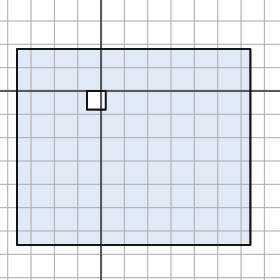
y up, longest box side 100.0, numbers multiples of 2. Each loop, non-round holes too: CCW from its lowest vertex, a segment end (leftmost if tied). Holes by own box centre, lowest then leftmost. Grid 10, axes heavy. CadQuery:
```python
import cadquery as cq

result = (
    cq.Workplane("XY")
    .moveTo(-36.0, -66.0)
    .lineTo(64.0, -66.0)
    .lineTo(64.0, 18.0)
    .lineTo(-36.0, 18.0)
    .close()
    .moveTo(-6.0, -8.0)
    .lineTo(2.0, -8.0)
    .lineTo(2.0, 0.0)
    .lineTo(-6.0, 0.0)
    .close()
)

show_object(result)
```